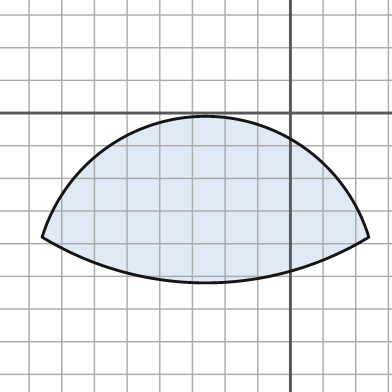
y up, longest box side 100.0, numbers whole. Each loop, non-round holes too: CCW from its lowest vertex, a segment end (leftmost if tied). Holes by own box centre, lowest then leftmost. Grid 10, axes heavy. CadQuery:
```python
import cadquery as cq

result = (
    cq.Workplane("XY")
    .moveTo(-76.0, -38.0)
    .threePointArc((-26.0, -52.0), (24.0, -38.0))
    .threePointArc((-26.0, -1.0), (-76.0, -38.0))
    .close()
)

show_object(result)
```